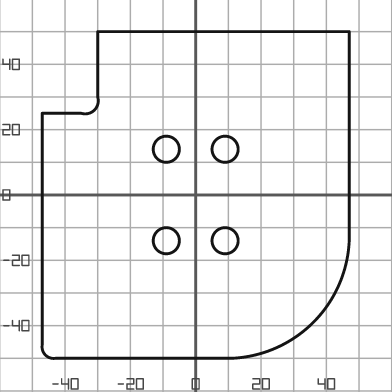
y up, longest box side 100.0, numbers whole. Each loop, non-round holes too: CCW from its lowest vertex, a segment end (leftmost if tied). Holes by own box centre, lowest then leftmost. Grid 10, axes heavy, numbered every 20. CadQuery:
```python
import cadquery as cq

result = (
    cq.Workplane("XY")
    .moveTo(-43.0, -50.0)
    .lineTo(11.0, -50.0)
    .threePointArc((36.0, -39.0), (47.0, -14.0))
    .lineTo(47.0, 50.0)
    .lineTo(-30.0, 50.0)
    .lineTo(-30.0, 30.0)
    .threePointArc((-31.0, 26.0), (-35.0, 25.0))
    .lineTo(-47.0, 25.0)
    .lineTo(-47.0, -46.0)
    .threePointArc((-46.0, -49.0), (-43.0, -50.0))
    .close()
    .moveTo(-9.0, -14.0)
    .circle(4.0)
    .moveTo(9.0, -14.0)
    .circle(4.0)
    .moveTo(-9.0, 14.0)
    .circle(4.0)
    .moveTo(9.0, 14.0)
    .circle(4.0)
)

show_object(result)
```